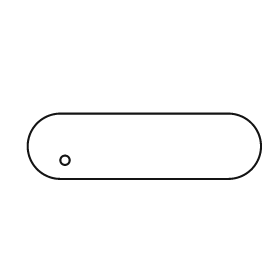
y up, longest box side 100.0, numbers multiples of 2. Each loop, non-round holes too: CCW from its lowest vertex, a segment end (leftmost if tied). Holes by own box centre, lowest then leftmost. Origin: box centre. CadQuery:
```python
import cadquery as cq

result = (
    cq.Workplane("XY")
    .moveTo(-36.0, -14.0)
    .lineTo(36.0, -14.0)
    .threePointArc((50.0, 0.0), (36.0, 14.0))
    .lineTo(-36.0, 14.0)
    .threePointArc((-50.0, 0.0), (-36.0, -14.0))
    .close()
    .moveTo(-34.0, -6.0)
    .circle(2.0)
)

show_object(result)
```